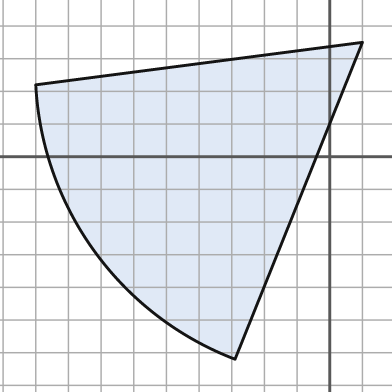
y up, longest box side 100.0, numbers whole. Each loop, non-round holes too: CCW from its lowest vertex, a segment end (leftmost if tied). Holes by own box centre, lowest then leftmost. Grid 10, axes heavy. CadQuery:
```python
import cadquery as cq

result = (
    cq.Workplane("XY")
    .moveTo(-29.0, -62.0)
    .lineTo(10.0, 35.0)
    .lineTo(-90.0, 22.0)
    .threePointArc((-72.0, -29.0), (-29.0, -62.0))
    .close()
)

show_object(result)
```